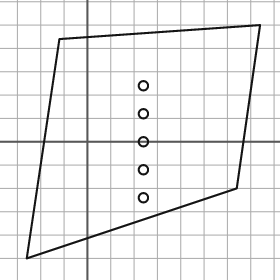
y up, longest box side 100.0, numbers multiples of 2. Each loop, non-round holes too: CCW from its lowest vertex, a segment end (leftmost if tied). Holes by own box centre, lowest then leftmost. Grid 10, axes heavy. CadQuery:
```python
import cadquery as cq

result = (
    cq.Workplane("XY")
    .moveTo(-26.0, -50.0)
    .lineTo(64.0, -20.0)
    .lineTo(74.0, 50.0)
    .lineTo(-12.0, 44.0)
    .close()
    .moveTo(24.0, -24.0)
    .circle(2.0)
    .moveTo(24.0, -12.0)
    .circle(2.0)
    .moveTo(24.0, 0.0)
    .circle(2.0)
    .moveTo(24.0, 12.0)
    .circle(2.0)
    .moveTo(24.0, 24.0)
    .circle(2.0)
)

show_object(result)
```